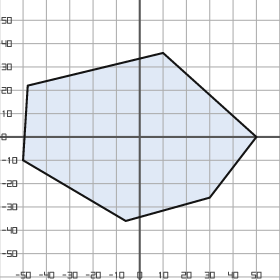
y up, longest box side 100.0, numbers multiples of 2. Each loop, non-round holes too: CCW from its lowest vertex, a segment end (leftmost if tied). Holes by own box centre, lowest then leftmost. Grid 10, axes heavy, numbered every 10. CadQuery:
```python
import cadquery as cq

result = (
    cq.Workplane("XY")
    .moveTo(-6.0, -36.0)
    .lineTo(30.0, -26.0)
    .lineTo(50.0, 0.0)
    .lineTo(10.0, 36.0)
    .lineTo(-48.0, 22.0)
    .lineTo(-50.0, -10.0)
    .close()
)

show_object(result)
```